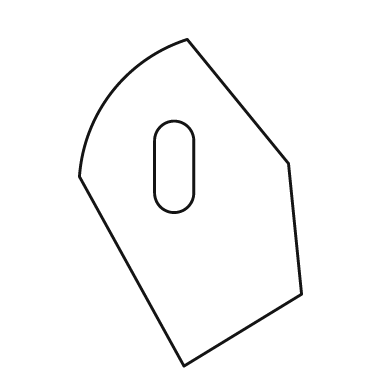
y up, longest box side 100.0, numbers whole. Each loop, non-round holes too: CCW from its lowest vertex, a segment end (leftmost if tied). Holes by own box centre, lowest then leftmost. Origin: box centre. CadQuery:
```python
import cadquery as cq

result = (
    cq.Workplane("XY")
    .moveTo(-2.0, -50.0)
    .lineTo(34.0, -28.0)
    .lineTo(30.0, 12.0)
    .lineTo(-1.0, 50.0)
    .threePointArc((-24.0, 34.0), (-34.0, 8.0))
    .close()
    .moveTo(-11.0, 3.0)
    .threePointArc((-5.0, -3.0), (1.0, 3.0))
    .lineTo(1.0, 19.0)
    .threePointArc((-5.0, 25.0), (-11.0, 19.0))
    .close()
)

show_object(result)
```